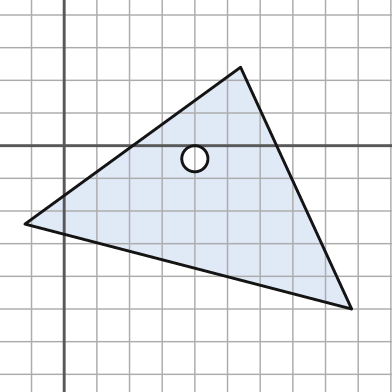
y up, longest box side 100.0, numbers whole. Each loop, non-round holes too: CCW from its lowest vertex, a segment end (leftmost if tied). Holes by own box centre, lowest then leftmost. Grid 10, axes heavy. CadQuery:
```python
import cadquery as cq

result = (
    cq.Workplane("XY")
    .moveTo(88.0, -50.0)
    .lineTo(54.0, 24.0)
    .lineTo(-12.0, -24.0)
    .close()
    .moveTo(40.0, -4.0)
    .circle(4.0)
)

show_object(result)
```